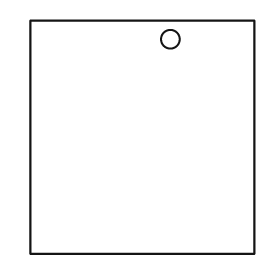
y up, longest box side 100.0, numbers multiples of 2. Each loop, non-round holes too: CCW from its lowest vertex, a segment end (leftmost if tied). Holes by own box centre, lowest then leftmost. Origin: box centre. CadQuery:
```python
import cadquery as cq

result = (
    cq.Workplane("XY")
    .moveTo(-48.0, -50.0)
    .lineTo(48.0, -50.0)
    .lineTo(48.0, 50.0)
    .lineTo(-48.0, 50.0)
    .close()
    .moveTo(12.0, 42.0)
    .circle(4.0)
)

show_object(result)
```